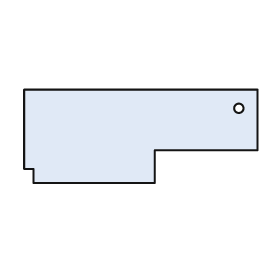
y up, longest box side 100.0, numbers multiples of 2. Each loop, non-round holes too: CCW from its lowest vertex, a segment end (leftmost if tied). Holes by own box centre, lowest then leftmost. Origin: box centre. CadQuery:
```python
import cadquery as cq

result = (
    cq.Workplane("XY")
    .moveTo(-46.0, -20.0)
    .lineTo(6.0, -20.0)
    .lineTo(6.0, -6.0)
    .lineTo(50.0, -6.0)
    .lineTo(50.0, 20.0)
    .lineTo(-50.0, 20.0)
    .lineTo(-50.0, -14.0)
    .lineTo(-46.0, -14.0)
    .close()
    .moveTo(42.0, 12.0)
    .circle(2.0)
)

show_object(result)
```